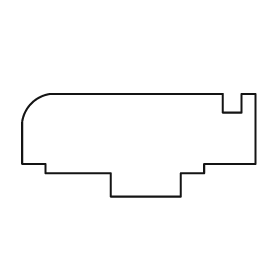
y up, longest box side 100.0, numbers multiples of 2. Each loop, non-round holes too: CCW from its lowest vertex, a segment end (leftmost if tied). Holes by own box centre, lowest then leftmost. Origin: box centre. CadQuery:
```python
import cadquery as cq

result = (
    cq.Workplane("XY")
    .moveTo(-12.0, -22.0)
    .lineTo(18.0, -22.0)
    .lineTo(18.0, -12.0)
    .lineTo(28.0, -12.0)
    .lineTo(28.0, -8.0)
    .lineTo(50.0, -8.0)
    .lineTo(50.0, 22.0)
    .lineTo(44.0, 22.0)
    .lineTo(44.0, 14.0)
    .lineTo(36.0, 14.0)
    .lineTo(36.0, 22.0)
    .lineTo(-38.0, 22.0)
    .threePointArc((-46.0, 18.0), (-50.0, 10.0))
    .lineTo(-50.0, -8.0)
    .lineTo(-40.0, -8.0)
    .lineTo(-40.0, -12.0)
    .lineTo(-12.0, -12.0)
    .close()
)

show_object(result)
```